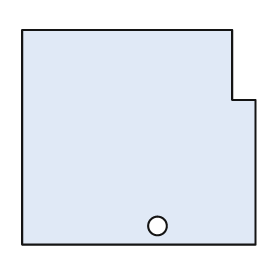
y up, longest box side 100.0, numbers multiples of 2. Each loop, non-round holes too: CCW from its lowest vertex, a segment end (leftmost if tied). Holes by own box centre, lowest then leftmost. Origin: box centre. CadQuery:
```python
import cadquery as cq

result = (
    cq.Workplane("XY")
    .moveTo(-50.0, -46.0)
    .lineTo(50.0, -46.0)
    .lineTo(50.0, 16.0)
    .lineTo(40.0, 16.0)
    .lineTo(40.0, 46.0)
    .lineTo(-50.0, 46.0)
    .close()
    .moveTo(8.0, -38.0)
    .circle(4.0)
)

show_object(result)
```